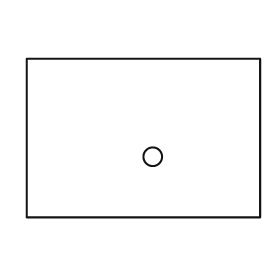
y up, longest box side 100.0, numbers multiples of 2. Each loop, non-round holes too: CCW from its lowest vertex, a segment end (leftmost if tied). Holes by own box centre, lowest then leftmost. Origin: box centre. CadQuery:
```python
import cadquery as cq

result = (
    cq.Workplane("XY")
    .moveTo(-50.0, -34.0)
    .lineTo(50.0, -34.0)
    .lineTo(50.0, 34.0)
    .lineTo(-50.0, 34.0)
    .close()
    .moveTo(4.0, -8.0)
    .circle(4.0)
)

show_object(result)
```